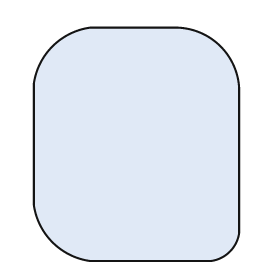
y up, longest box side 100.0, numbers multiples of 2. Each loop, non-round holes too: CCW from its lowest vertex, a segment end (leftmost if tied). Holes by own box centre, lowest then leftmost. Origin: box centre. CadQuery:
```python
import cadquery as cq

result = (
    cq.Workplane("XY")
    .moveTo(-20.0, -50.0)
    .lineTo(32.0, -50.0)
    .threePointArc((40.0, -46.0), (44.0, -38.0))
    .lineTo(44.0, 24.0)
    .threePointArc((36.0, 42.0), (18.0, 50.0))
    .lineTo(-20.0, 50.0)
    .threePointArc((-36.0, 42.0), (-44.0, 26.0))
    .lineTo(-44.0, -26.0)
    .threePointArc((-36.0, -42.0), (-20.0, -50.0))
    .close()
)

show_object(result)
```